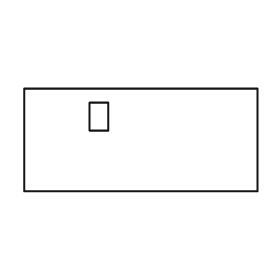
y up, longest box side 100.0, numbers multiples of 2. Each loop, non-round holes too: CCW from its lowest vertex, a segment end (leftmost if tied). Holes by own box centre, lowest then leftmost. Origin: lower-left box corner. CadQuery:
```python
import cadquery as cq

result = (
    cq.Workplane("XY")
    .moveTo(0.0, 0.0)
    .lineTo(100.0, 0.0)
    .lineTo(100.0, 44.0)
    .lineTo(0.0, 44.0)
    .close()
    .moveTo(28.0, 26.0)
    .lineTo(36.0, 26.0)
    .lineTo(36.0, 38.0)
    .lineTo(28.0, 38.0)
    .close()
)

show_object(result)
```